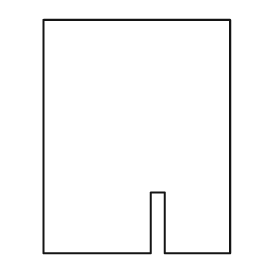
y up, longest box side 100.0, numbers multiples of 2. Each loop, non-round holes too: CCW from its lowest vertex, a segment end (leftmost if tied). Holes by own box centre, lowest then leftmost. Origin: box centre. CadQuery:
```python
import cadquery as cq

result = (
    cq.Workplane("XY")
    .moveTo(-40.0, -50.0)
    .lineTo(6.0, -50.0)
    .lineTo(6.0, -24.0)
    .lineTo(12.0, -24.0)
    .lineTo(12.0, -50.0)
    .lineTo(40.0, -50.0)
    .lineTo(40.0, 50.0)
    .lineTo(-40.0, 50.0)
    .close()
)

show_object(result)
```